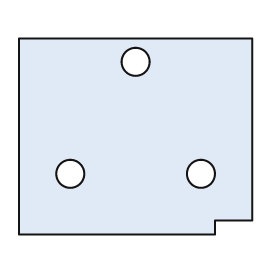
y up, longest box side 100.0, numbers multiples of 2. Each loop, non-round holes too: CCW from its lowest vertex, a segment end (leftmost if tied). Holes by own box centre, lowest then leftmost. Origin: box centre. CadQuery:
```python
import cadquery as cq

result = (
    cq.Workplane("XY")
    .moveTo(-50.0, -42.0)
    .lineTo(34.0, -42.0)
    .lineTo(34.0, -36.0)
    .lineTo(50.0, -36.0)
    .lineTo(50.0, 42.0)
    .lineTo(-50.0, 42.0)
    .close()
    .moveTo(-28.0, -16.0)
    .circle(6.0)
    .moveTo(28.0, -16.0)
    .circle(6.0)
    .moveTo(0.0, 32.0)
    .circle(6.0)
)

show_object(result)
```